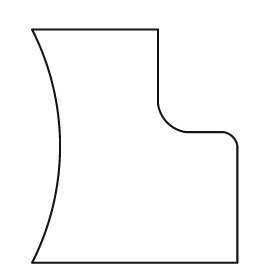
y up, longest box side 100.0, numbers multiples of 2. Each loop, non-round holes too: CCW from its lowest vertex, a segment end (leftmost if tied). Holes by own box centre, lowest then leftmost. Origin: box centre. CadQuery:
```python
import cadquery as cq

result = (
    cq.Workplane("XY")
    .moveTo(-44.0, -50.0)
    .lineTo(44.0, -50.0)
    .lineTo(44.0, 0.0)
    .threePointArc((42.0, 4.0), (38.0, 6.0))
    .lineTo(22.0, 6.0)
    .threePointArc((14.0, 10.0), (10.0, 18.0))
    .lineTo(10.0, 50.0)
    .lineTo(-44.0, 50.0)
    .threePointArc((-32.0, 0.0), (-44.0, -50.0))
    .close()
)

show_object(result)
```